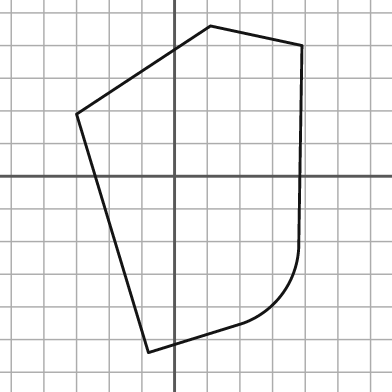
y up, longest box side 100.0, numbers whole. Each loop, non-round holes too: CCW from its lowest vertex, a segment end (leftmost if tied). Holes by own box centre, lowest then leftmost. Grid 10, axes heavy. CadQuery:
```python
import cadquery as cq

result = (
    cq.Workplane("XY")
    .moveTo(-8.0, -54.0)
    .lineTo(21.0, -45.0)
    .threePointArc((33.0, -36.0), (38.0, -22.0))
    .lineTo(39.0, 40.0)
    .lineTo(11.0, 46.0)
    .lineTo(-30.0, 19.0)
    .close()
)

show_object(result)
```